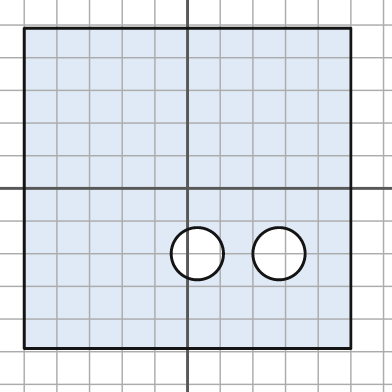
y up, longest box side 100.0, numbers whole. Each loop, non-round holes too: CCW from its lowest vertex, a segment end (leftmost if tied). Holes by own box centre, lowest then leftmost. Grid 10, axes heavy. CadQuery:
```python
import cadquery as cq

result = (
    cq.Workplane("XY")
    .moveTo(-50.0, -49.0)
    .lineTo(50.0, -49.0)
    .lineTo(50.0, 49.0)
    .lineTo(-50.0, 49.0)
    .close()
    .moveTo(3.0, -20.0)
    .circle(8.0)
    .moveTo(28.0, -20.0)
    .circle(8.0)
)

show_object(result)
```